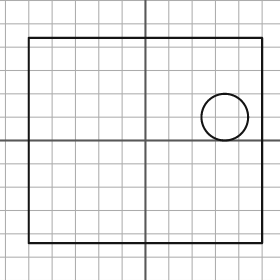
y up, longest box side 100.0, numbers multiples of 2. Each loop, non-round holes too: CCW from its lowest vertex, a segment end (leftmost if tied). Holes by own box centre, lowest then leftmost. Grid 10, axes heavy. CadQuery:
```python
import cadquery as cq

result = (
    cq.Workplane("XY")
    .moveTo(-50.0, -44.0)
    .lineTo(50.0, -44.0)
    .lineTo(50.0, 44.0)
    .lineTo(-50.0, 44.0)
    .close()
    .moveTo(34.0, 10.0)
    .circle(10.0)
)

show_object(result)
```